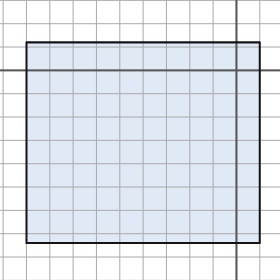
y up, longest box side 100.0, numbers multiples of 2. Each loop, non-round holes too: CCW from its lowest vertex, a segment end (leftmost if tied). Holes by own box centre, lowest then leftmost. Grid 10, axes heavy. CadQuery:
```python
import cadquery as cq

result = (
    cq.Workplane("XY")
    .moveTo(-90.0, -74.0)
    .lineTo(10.0, -74.0)
    .lineTo(10.0, 12.0)
    .lineTo(-90.0, 12.0)
    .close()
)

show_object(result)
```